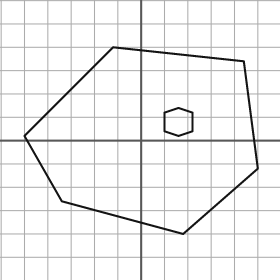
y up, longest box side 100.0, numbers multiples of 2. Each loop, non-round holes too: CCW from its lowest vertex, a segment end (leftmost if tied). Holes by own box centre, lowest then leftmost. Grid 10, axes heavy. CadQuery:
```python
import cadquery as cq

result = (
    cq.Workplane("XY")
    .moveTo(18.0, -40.0)
    .lineTo(50.0, -12.0)
    .lineTo(44.0, 34.0)
    .lineTo(-12.0, 40.0)
    .lineTo(-50.0, 2.0)
    .lineTo(-34.0, -26.0)
    .close()
    .moveTo(16.0, 2.0)
    .lineTo(22.0, 4.0)
    .lineTo(22.0, 12.0)
    .lineTo(16.0, 14.0)
    .lineTo(10.0, 12.0)
    .lineTo(10.0, 4.0)
    .close()
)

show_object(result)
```